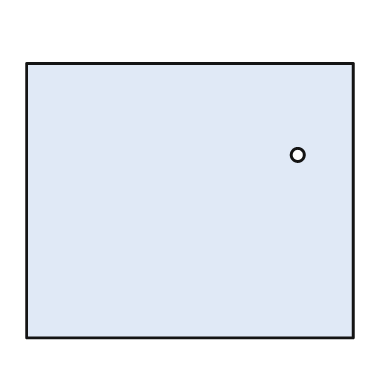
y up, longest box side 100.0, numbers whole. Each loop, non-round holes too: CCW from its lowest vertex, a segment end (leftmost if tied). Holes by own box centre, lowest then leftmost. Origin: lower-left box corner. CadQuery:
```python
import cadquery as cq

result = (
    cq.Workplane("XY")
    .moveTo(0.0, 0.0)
    .lineTo(100.0, 0.0)
    .lineTo(100.0, 84.0)
    .lineTo(0.0, 84.0)
    .close()
    .moveTo(83.0, 56.0)
    .circle(2.0)
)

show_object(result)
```